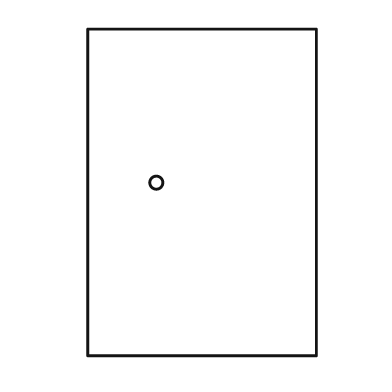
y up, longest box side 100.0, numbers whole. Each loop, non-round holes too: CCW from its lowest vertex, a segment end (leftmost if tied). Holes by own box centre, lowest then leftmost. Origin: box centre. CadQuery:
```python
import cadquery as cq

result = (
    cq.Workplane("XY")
    .moveTo(-35.0, -50.0)
    .lineTo(35.0, -50.0)
    .lineTo(35.0, 50.0)
    .lineTo(-35.0, 50.0)
    .close()
    .moveTo(-14.0, 3.0)
    .circle(2.0)
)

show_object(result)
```